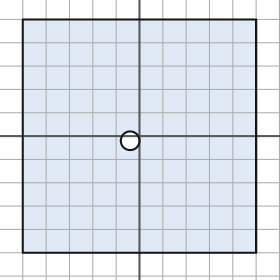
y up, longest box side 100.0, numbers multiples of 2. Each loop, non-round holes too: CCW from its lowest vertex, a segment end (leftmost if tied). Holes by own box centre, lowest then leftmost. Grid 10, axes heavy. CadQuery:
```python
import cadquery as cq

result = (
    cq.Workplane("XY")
    .moveTo(-50.0, -50.0)
    .lineTo(50.0, -50.0)
    .lineTo(50.0, 50.0)
    .lineTo(-50.0, 50.0)
    .close()
    .moveTo(-4.0, -2.0)
    .circle(4.0)
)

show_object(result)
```